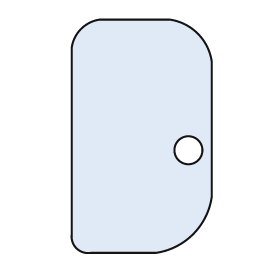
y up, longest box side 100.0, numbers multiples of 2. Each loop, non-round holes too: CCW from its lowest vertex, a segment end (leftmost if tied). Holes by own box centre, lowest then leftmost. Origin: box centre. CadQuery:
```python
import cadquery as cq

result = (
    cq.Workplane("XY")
    .moveTo(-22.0, -50.0)
    .lineTo(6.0, -50.0)
    .threePointArc((22.0, -42.0), (30.0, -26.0))
    .lineTo(30.0, 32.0)
    .threePointArc((24.0, 44.0), (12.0, 50.0))
    .lineTo(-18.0, 50.0)
    .threePointArc((-26.0, 46.0), (-30.0, 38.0))
    .lineTo(-30.0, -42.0)
    .threePointArc((-28.0, -48.0), (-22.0, -50.0))
    .close()
    .moveTo(20.0, -6.0)
    .circle(6.0)
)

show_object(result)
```